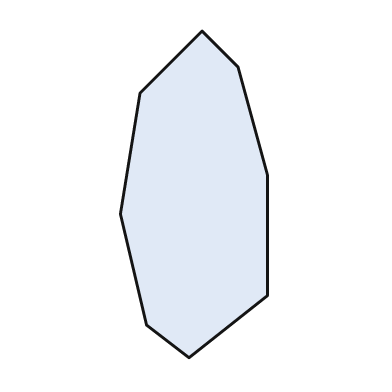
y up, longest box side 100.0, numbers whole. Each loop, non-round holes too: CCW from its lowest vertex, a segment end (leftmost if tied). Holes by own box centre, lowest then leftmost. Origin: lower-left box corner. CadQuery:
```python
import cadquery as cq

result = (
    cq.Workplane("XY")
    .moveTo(21.0, 0.0)
    .lineTo(45.0, 19.0)
    .lineTo(45.0, 56.0)
    .lineTo(36.0, 89.0)
    .lineTo(25.0, 100.0)
    .lineTo(6.0, 81.0)
    .lineTo(0.0, 44.0)
    .lineTo(8.0, 10.0)
    .close()
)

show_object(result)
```